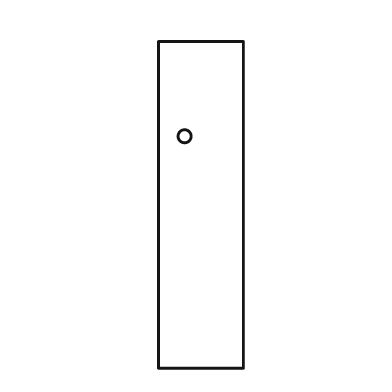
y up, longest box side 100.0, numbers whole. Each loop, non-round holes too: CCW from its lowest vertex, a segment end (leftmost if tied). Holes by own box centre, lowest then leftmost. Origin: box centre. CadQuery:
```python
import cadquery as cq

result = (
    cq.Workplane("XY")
    .moveTo(-13.0, -50.0)
    .lineTo(13.0, -50.0)
    .lineTo(13.0, 50.0)
    .lineTo(-13.0, 50.0)
    .close()
    .moveTo(-5.0, 21.0)
    .circle(2.0)
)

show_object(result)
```